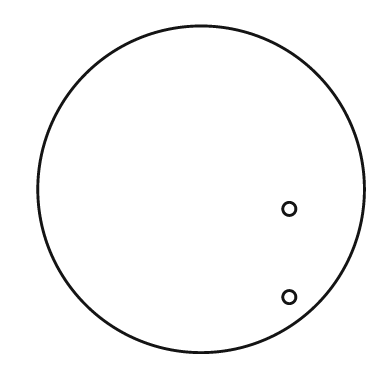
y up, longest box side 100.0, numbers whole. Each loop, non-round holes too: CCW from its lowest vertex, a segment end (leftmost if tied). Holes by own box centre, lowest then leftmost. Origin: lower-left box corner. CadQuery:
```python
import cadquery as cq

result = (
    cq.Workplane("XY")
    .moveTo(50.0, 50.0)
    .circle(50.0)
    .moveTo(77.0, 17.0)
    .circle(2.0)
    .moveTo(77.0, 44.0)
    .circle(2.0)
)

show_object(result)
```